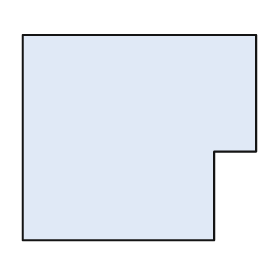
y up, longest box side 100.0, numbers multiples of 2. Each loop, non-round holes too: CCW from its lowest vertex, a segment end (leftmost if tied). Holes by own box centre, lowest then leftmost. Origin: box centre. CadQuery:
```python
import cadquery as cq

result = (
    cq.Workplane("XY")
    .moveTo(-50.0, -44.0)
    .lineTo(32.0, -44.0)
    .lineTo(32.0, -6.0)
    .lineTo(50.0, -6.0)
    .lineTo(50.0, 44.0)
    .lineTo(-50.0, 44.0)
    .close()
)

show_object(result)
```